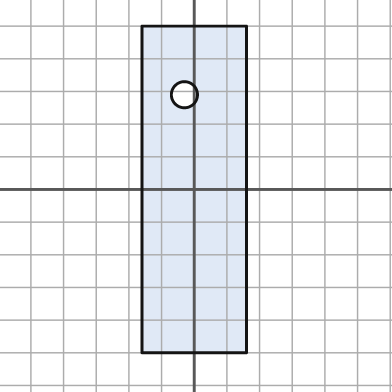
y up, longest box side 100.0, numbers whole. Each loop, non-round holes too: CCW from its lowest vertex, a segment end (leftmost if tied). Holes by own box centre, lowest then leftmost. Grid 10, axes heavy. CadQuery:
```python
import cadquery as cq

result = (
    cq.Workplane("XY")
    .moveTo(-16.0, -50.0)
    .lineTo(16.0, -50.0)
    .lineTo(16.0, 50.0)
    .lineTo(-16.0, 50.0)
    .close()
    .moveTo(-3.0, 29.0)
    .circle(4.0)
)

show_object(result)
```